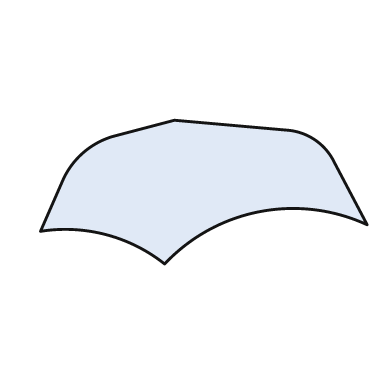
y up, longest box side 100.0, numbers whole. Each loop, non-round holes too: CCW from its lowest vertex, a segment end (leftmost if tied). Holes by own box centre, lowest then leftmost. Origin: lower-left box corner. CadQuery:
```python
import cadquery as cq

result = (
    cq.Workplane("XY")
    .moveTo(38.0, 0.0)
    .threePointArc((67.0, 16.0), (100.0, 12.0))
    .lineTo(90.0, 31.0)
    .threePointArc((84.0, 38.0), (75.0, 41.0))
    .lineTo(41.0, 44.0)
    .lineTo(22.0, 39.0)
    .threePointArc((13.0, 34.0), (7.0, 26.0))
    .lineTo(0.0, 10.0)
    .threePointArc((20.0, 9.0), (38.0, 0.0))
    .close()
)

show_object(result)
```